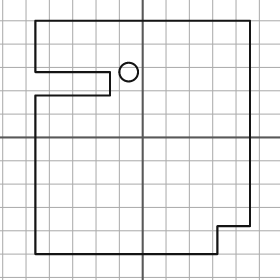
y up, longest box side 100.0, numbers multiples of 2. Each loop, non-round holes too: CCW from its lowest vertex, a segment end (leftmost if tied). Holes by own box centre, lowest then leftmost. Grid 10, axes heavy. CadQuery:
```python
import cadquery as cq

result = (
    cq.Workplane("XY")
    .moveTo(-46.0, -50.0)
    .lineTo(32.0, -50.0)
    .lineTo(32.0, -38.0)
    .lineTo(46.0, -38.0)
    .lineTo(46.0, 50.0)
    .lineTo(-46.0, 50.0)
    .lineTo(-46.0, 28.0)
    .lineTo(-14.0, 28.0)
    .lineTo(-14.0, 18.0)
    .lineTo(-46.0, 18.0)
    .close()
    .moveTo(-6.0, 28.0)
    .circle(4.0)
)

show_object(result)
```